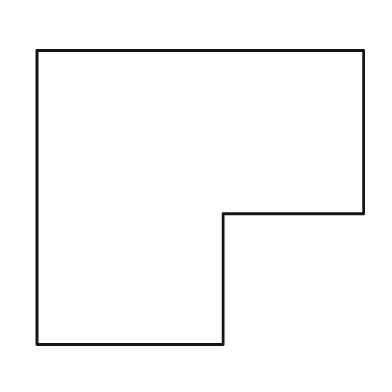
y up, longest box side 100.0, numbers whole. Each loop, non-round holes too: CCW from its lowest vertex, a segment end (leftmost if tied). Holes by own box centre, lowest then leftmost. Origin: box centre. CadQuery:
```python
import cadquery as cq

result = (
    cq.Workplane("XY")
    .moveTo(-50.0, -45.0)
    .lineTo(7.0, -45.0)
    .lineTo(7.0, -5.0)
    .lineTo(50.0, -5.0)
    .lineTo(50.0, 45.0)
    .lineTo(-50.0, 45.0)
    .close()
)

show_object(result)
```